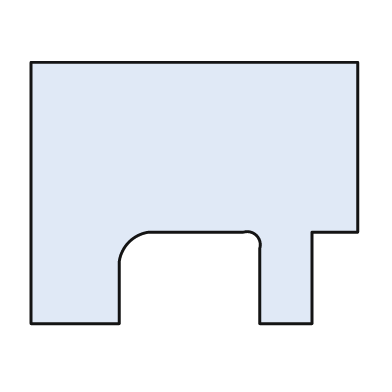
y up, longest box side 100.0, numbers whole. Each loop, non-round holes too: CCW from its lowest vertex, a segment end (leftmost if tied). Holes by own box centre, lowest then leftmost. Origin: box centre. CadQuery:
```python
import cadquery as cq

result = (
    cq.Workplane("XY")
    .moveTo(-50.0, -40.0)
    .lineTo(-23.0, -40.0)
    .lineTo(-23.0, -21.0)
    .threePointArc((-20.0, -15.0), (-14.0, -12.0))
    .lineTo(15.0, -12.0)
    .threePointArc((19.0, -13.0), (20.0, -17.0))
    .lineTo(20.0, -40.0)
    .lineTo(36.0, -40.0)
    .lineTo(36.0, -12.0)
    .lineTo(50.0, -12.0)
    .lineTo(50.0, 40.0)
    .lineTo(-50.0, 40.0)
    .close()
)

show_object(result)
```